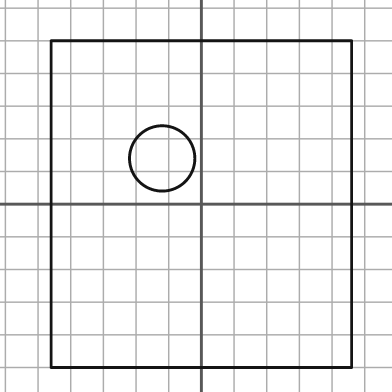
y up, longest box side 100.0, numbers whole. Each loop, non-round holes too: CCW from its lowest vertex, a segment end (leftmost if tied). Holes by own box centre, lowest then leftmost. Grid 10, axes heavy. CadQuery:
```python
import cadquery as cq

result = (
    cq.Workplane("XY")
    .moveTo(-46.0, -50.0)
    .lineTo(46.0, -50.0)
    .lineTo(46.0, 50.0)
    .lineTo(-46.0, 50.0)
    .close()
    .moveTo(-12.0, 14.0)
    .circle(10.0)
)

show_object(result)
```